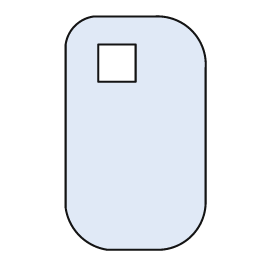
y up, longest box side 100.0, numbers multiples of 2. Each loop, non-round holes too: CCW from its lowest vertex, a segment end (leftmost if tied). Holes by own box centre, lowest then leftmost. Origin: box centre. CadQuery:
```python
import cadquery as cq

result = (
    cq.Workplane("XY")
    .moveTo(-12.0, -50.0)
    .lineTo(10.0, -50.0)
    .threePointArc((24.0, -44.0), (30.0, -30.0))
    .lineTo(30.0, 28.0)
    .threePointArc((24.0, 44.0), (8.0, 50.0))
    .lineTo(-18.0, 50.0)
    .threePointArc((-26.0, 46.0), (-30.0, 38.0))
    .lineTo(-30.0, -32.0)
    .threePointArc((-24.0, -44.0), (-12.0, -50.0))
    .close()
    .moveTo(-16.0, 22.0)
    .lineTo(0.0, 22.0)
    .lineTo(0.0, 38.0)
    .lineTo(-16.0, 38.0)
    .close()
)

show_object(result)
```